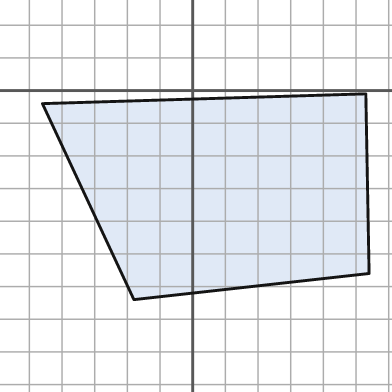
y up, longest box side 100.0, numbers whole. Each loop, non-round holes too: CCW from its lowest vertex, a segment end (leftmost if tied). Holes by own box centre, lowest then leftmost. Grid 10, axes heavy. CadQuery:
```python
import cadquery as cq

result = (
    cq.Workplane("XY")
    .moveTo(-18.0, -64.0)
    .lineTo(54.0, -56.0)
    .lineTo(53.0, -1.0)
    .lineTo(-46.0, -4.0)
    .close()
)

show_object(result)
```